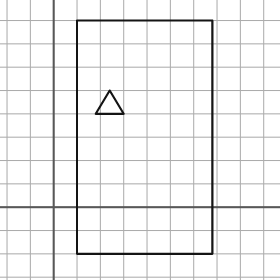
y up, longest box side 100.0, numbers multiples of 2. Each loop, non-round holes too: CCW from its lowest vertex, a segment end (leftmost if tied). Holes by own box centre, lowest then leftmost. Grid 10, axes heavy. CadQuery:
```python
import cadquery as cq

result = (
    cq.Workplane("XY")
    .moveTo(10.0, -20.0)
    .lineTo(68.0, -20.0)
    .lineTo(68.0, 80.0)
    .lineTo(10.0, 80.0)
    .close()
    .moveTo(18.0, 40.0)
    .lineTo(30.0, 40.0)
    .lineTo(24.0, 50.0)
    .close()
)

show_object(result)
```